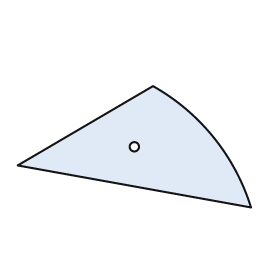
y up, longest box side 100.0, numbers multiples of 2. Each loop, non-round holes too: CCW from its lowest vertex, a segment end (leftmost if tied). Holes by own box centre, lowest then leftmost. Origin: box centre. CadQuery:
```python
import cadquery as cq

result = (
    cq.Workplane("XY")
    .moveTo(50.0, -26.0)
    .threePointArc((34.0, 4.0), (8.0, 26.0))
    .lineTo(-50.0, -8.0)
    .close()
    .moveTo(0.0, 0.0)
    .circle(2.0)
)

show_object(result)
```